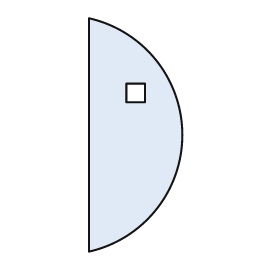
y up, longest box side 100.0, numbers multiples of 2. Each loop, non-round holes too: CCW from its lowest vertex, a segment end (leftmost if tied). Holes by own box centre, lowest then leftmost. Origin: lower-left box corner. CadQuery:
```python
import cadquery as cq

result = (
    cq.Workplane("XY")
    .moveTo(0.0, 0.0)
    .threePointArc((40.0, 50.0), (0.0, 100.0))
    .close()
    .moveTo(16.0, 64.0)
    .lineTo(24.0, 64.0)
    .lineTo(24.0, 72.0)
    .lineTo(16.0, 72.0)
    .close()
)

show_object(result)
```